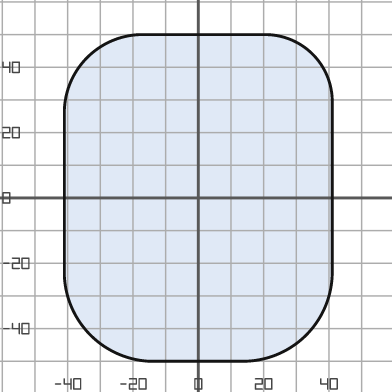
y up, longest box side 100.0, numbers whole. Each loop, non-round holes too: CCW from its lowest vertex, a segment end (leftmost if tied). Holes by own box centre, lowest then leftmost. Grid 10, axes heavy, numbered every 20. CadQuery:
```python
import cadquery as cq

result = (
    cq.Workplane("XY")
    .moveTo(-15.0, -50.0)
    .lineTo(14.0, -50.0)
    .threePointArc((33.0, -42.0), (41.0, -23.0))
    .lineTo(41.0, 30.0)
    .threePointArc((35.0, 44.0), (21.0, 50.0))
    .lineTo(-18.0, 50.0)
    .threePointArc((-34.0, 43.0), (-41.0, 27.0))
    .lineTo(-41.0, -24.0)
    .threePointArc((-33.0, -42.0), (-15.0, -50.0))
    .close()
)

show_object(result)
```